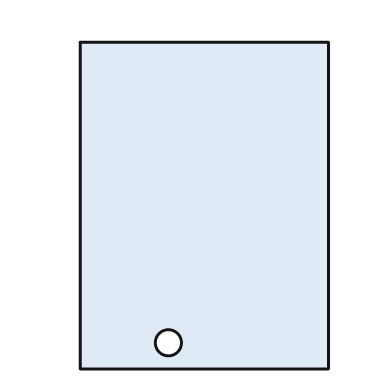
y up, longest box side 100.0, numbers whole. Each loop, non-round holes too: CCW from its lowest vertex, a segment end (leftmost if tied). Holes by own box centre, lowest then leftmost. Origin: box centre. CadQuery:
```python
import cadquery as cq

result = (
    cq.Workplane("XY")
    .moveTo(-38.0, -50.0)
    .lineTo(38.0, -50.0)
    .lineTo(38.0, 50.0)
    .lineTo(-38.0, 50.0)
    .close()
    .moveTo(-11.0, -42.0)
    .circle(4.0)
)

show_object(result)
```